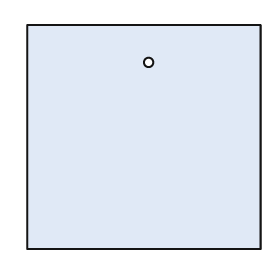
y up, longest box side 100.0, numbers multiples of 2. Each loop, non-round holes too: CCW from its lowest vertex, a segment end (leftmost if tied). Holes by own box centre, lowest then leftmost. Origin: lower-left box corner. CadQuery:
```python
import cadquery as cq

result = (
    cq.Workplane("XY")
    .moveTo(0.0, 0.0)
    .lineTo(100.0, 0.0)
    .lineTo(100.0, 96.0)
    .lineTo(0.0, 96.0)
    .close()
    .moveTo(52.0, 80.0)
    .circle(2.0)
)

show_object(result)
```